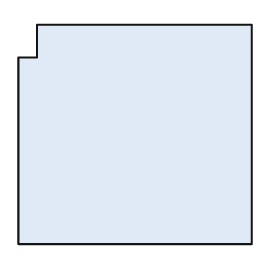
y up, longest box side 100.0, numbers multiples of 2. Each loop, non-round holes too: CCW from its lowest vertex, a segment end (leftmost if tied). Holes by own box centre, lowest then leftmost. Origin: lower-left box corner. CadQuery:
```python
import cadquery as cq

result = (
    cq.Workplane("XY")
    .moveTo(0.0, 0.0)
    .lineTo(100.0, 0.0)
    .lineTo(100.0, 94.0)
    .lineTo(8.0, 94.0)
    .lineTo(8.0, 80.0)
    .lineTo(0.0, 80.0)
    .close()
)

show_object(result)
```